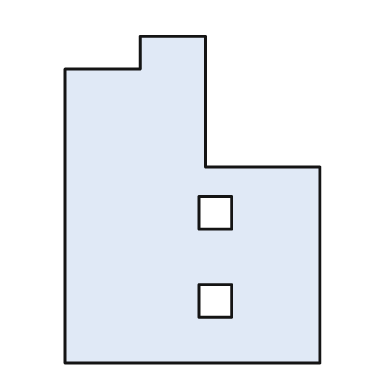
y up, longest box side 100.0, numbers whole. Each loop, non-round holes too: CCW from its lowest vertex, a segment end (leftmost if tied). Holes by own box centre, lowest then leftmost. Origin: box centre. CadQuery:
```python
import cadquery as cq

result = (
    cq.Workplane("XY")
    .moveTo(-39.0, -50.0)
    .lineTo(39.0, -50.0)
    .lineTo(39.0, 10.0)
    .lineTo(4.0, 10.0)
    .lineTo(4.0, 50.0)
    .lineTo(-16.0, 50.0)
    .lineTo(-16.0, 40.0)
    .lineTo(-39.0, 40.0)
    .close()
    .moveTo(2.0, -36.0)
    .lineTo(12.0, -36.0)
    .lineTo(12.0, -26.0)
    .lineTo(2.0, -26.0)
    .close()
    .moveTo(2.0, -9.0)
    .lineTo(12.0, -9.0)
    .lineTo(12.0, 1.0)
    .lineTo(2.0, 1.0)
    .close()
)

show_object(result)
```